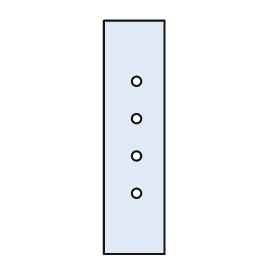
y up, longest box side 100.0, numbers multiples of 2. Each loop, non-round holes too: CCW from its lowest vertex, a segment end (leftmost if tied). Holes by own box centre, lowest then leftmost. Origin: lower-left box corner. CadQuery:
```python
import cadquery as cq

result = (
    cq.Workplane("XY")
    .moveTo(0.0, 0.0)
    .lineTo(26.0, 0.0)
    .lineTo(26.0, 100.0)
    .lineTo(0.0, 100.0)
    .close()
    .moveTo(14.0, 26.0)
    .circle(2.0)
    .moveTo(14.0, 42.0)
    .circle(2.0)
    .moveTo(14.0, 58.0)
    .circle(2.0)
    .moveTo(14.0, 74.0)
    .circle(2.0)
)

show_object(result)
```